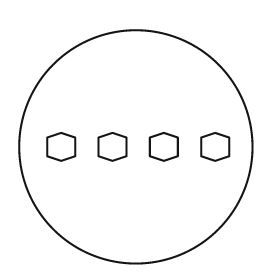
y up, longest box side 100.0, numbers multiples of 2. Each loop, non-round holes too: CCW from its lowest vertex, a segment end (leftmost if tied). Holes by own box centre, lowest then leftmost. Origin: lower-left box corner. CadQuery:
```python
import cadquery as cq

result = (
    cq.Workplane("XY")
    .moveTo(50.0, 50.0)
    .circle(50.0)
    .moveTo(18.0, 44.0)
    .lineTo(24.0, 46.0)
    .lineTo(24.0, 54.0)
    .lineTo(18.0, 56.0)
    .lineTo(12.0, 54.0)
    .lineTo(12.0, 46.0)
    .close()
    .moveTo(40.0, 44.0)
    .lineTo(46.0, 46.0)
    .lineTo(46.0, 54.0)
    .lineTo(40.0, 56.0)
    .lineTo(34.0, 54.0)
    .lineTo(34.0, 46.0)
    .close()
    .moveTo(62.0, 44.0)
    .lineTo(68.0, 46.0)
    .lineTo(68.0, 54.0)
    .lineTo(62.0, 56.0)
    .lineTo(56.0, 54.0)
    .lineTo(56.0, 46.0)
    .close()
    .moveTo(84.0, 44.0)
    .lineTo(90.0, 46.0)
    .lineTo(90.0, 54.0)
    .lineTo(84.0, 56.0)
    .lineTo(78.0, 54.0)
    .lineTo(78.0, 46.0)
    .close()
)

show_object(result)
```